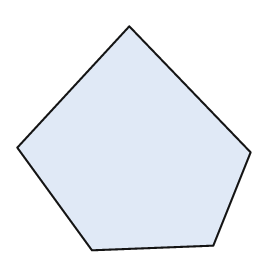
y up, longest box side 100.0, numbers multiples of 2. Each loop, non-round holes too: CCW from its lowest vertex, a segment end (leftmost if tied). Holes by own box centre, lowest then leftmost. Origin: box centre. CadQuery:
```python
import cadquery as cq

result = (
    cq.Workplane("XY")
    .moveTo(-18.0, -48.0)
    .lineTo(34.0, -46.0)
    .lineTo(50.0, -6.0)
    .lineTo(-2.0, 48.0)
    .lineTo(-50.0, -4.0)
    .close()
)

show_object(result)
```